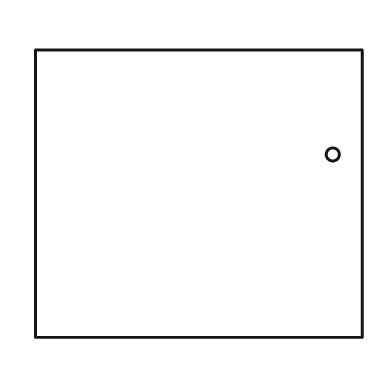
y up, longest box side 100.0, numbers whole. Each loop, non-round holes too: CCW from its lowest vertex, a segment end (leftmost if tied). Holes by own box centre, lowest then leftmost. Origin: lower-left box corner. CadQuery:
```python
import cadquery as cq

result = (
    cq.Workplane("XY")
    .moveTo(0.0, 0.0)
    .lineTo(100.0, 0.0)
    .lineTo(100.0, 88.0)
    .lineTo(0.0, 88.0)
    .close()
    .moveTo(91.0, 56.0)
    .circle(2.0)
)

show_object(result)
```